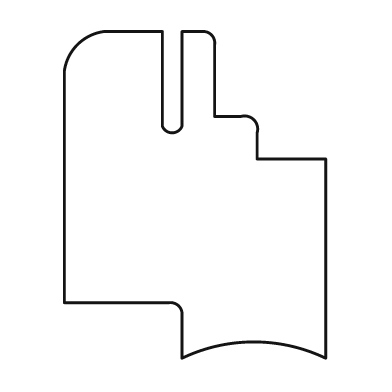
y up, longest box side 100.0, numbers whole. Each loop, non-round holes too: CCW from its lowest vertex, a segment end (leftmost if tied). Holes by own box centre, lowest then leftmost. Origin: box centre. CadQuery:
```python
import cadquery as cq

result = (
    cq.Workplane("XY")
    .moveTo(-4.0, -50.0)
    .threePointArc((18.0, -45.0), (40.0, -50.0))
    .lineTo(40.0, 11.0)
    .lineTo(19.0, 11.0)
    .lineTo(19.0, 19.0)
    .threePointArc((18.0, 23.0), (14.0, 24.0))
    .lineTo(6.0, 24.0)
    .lineTo(6.0, 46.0)
    .threePointArc((5.0, 49.0), (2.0, 50.0))
    .lineTo(-4.0, 50.0)
    .lineTo(-4.0, 21.0)
    .threePointArc((-7.0, 19.0), (-10.0, 21.0))
    .lineTo(-10.0, 50.0)
    .lineTo(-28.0, 50.0)
    .threePointArc((-36.0, 46.0), (-40.0, 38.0))
    .lineTo(-40.0, -33.0)
    .lineTo(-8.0, -33.0)
    .threePointArc((-5.0, -34.0), (-4.0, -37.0))
    .close()
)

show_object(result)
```